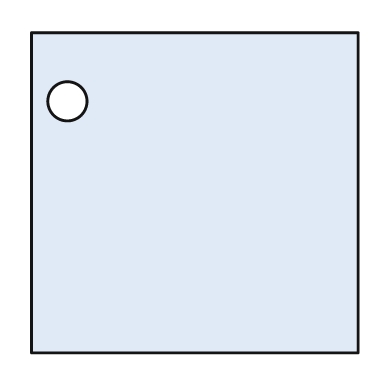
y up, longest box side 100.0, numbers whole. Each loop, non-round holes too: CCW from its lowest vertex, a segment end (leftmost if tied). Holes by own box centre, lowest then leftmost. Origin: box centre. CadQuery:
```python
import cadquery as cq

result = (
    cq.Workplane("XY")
    .moveTo(-50.0, -49.0)
    .lineTo(50.0, -49.0)
    .lineTo(50.0, 49.0)
    .lineTo(-50.0, 49.0)
    .close()
    .moveTo(-39.0, 28.0)
    .circle(6.0)
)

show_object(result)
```